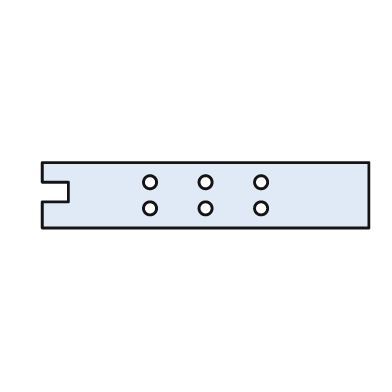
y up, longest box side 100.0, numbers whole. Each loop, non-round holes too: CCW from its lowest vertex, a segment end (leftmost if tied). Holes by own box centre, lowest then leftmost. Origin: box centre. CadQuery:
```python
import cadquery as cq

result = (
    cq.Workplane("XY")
    .moveTo(-50.0, -10.0)
    .lineTo(50.0, -10.0)
    .lineTo(50.0, 10.0)
    .lineTo(-50.0, 10.0)
    .lineTo(-50.0, 4.0)
    .lineTo(-42.0, 4.0)
    .lineTo(-42.0, -2.0)
    .lineTo(-50.0, -2.0)
    .close()
    .moveTo(-17.0, -4.0)
    .circle(2.0)
    .moveTo(0.0, -4.0)
    .circle(2.0)
    .moveTo(17.0, -4.0)
    .circle(2.0)
    .moveTo(-17.0, 4.0)
    .circle(2.0)
    .moveTo(0.0, 4.0)
    .circle(2.0)
    .moveTo(17.0, 4.0)
    .circle(2.0)
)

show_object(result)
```